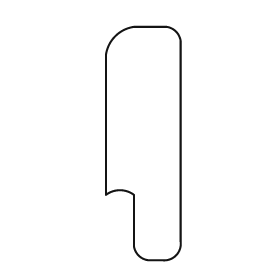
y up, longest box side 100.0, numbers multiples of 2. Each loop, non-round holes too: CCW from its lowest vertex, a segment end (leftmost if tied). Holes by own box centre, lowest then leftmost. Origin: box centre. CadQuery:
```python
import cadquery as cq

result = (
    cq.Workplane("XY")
    .moveTo(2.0, -50.0)
    .lineTo(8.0, -50.0)
    .threePointArc((14.0, -48.0), (16.0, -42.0))
    .lineTo(16.0, 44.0)
    .threePointArc((14.0, 48.0), (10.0, 50.0))
    .lineTo(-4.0, 50.0)
    .threePointArc((-12.0, 46.0), (-16.0, 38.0))
    .lineTo(-16.0, -22.0)
    .threePointArc((-10.0, -20.0), (-4.0, -22.0))
    .lineTo(-4.0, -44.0)
    .threePointArc((-2.0, -48.0), (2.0, -50.0))
    .close()
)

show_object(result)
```